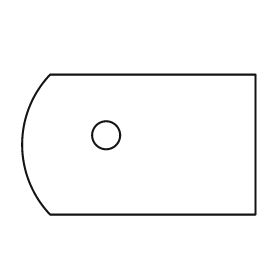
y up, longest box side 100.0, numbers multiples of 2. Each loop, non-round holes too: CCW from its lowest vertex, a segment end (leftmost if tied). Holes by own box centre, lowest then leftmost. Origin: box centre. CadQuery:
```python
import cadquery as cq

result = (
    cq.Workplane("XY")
    .moveTo(-38.0, -30.0)
    .lineTo(50.0, -30.0)
    .lineTo(50.0, 30.0)
    .lineTo(-38.0, 30.0)
    .threePointArc((-50.0, 0.0), (-38.0, -30.0))
    .close()
    .moveTo(-14.0, 4.0)
    .circle(6.0)
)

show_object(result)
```